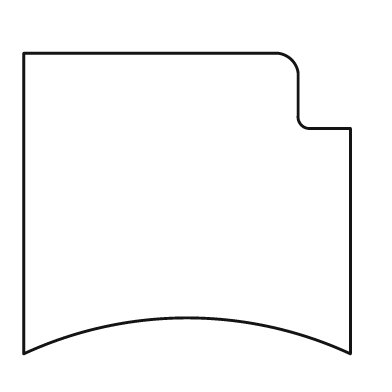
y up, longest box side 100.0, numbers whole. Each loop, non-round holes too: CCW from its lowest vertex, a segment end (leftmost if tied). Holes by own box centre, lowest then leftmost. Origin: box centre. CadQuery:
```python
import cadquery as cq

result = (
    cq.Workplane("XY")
    .moveTo(-50.0, -46.0)
    .threePointArc((0.0, -35.0), (50.0, -46.0))
    .lineTo(50.0, 23.0)
    .lineTo(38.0, 23.0)
    .threePointArc((35.0, 24.0), (34.0, 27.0))
    .lineTo(34.0, 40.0)
    .threePointArc((32.0, 44.0), (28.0, 46.0))
    .lineTo(-50.0, 46.0)
    .close()
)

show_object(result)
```